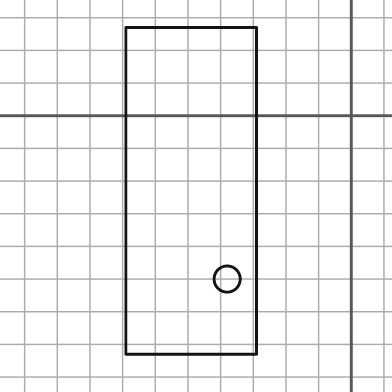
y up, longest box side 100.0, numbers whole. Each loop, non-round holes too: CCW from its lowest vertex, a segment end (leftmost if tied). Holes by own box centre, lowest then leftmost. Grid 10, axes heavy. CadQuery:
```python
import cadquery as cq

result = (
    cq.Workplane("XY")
    .moveTo(-69.0, -73.0)
    .lineTo(-29.0, -73.0)
    .lineTo(-29.0, 27.0)
    .lineTo(-69.0, 27.0)
    .close()
    .moveTo(-38.0, -50.0)
    .circle(4.0)
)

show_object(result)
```